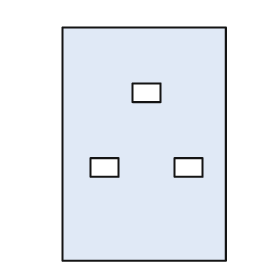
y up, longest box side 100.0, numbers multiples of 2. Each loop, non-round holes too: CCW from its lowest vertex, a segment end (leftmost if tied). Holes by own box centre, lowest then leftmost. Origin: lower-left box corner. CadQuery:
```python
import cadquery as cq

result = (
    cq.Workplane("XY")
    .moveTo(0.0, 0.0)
    .lineTo(70.0, 0.0)
    .lineTo(70.0, 100.0)
    .lineTo(0.0, 100.0)
    .close()
    .moveTo(12.0, 36.0)
    .lineTo(24.0, 36.0)
    .lineTo(24.0, 44.0)
    .lineTo(12.0, 44.0)
    .close()
    .moveTo(48.0, 36.0)
    .lineTo(60.0, 36.0)
    .lineTo(60.0, 44.0)
    .lineTo(48.0, 44.0)
    .close()
    .moveTo(30.0, 68.0)
    .lineTo(42.0, 68.0)
    .lineTo(42.0, 76.0)
    .lineTo(30.0, 76.0)
    .close()
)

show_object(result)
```